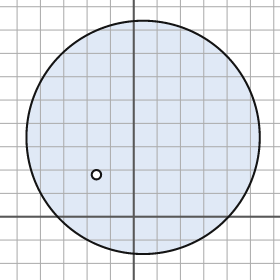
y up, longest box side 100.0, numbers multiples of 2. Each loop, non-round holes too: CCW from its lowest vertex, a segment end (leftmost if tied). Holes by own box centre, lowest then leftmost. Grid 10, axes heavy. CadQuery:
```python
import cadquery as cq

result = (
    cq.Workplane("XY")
    .moveTo(4.0, 34.0)
    .circle(50.0)
    .moveTo(-16.0, 18.0)
    .circle(2.0)
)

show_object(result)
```